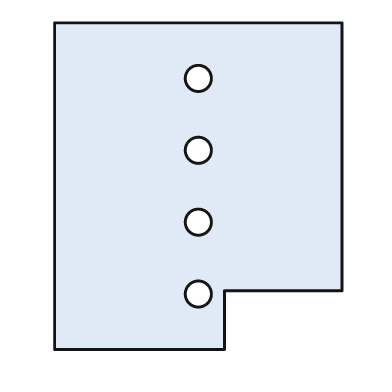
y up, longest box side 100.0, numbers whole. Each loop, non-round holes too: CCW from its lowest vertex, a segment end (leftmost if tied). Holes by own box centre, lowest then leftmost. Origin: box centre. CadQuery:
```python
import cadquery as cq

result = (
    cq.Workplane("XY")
    .moveTo(-44.0, -50.0)
    .lineTo(8.0, -50.0)
    .lineTo(8.0, -32.0)
    .lineTo(44.0, -32.0)
    .lineTo(44.0, 50.0)
    .lineTo(-44.0, 50.0)
    .close()
    .moveTo(0.0, -33.0)
    .circle(4.0)
    .moveTo(0.0, -11.0)
    .circle(4.0)
    .moveTo(0.0, 11.0)
    .circle(4.0)
    .moveTo(0.0, 33.0)
    .circle(4.0)
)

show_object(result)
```